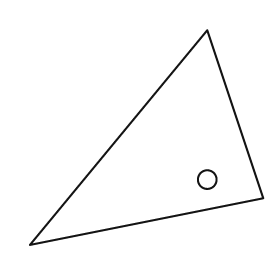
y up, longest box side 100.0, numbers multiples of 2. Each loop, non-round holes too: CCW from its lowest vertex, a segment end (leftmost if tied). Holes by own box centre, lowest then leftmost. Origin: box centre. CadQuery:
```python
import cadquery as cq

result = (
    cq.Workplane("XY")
    .moveTo(-50.0, -46.0)
    .lineTo(50.0, -26.0)
    .lineTo(26.0, 46.0)
    .close()
    .moveTo(26.0, -18.0)
    .circle(4.0)
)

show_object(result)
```